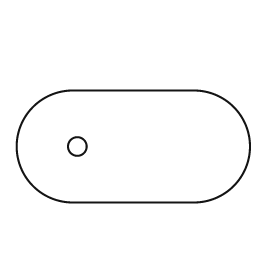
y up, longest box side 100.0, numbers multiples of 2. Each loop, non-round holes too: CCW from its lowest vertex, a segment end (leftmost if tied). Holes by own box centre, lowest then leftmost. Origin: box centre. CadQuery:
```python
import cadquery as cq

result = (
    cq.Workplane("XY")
    .moveTo(-26.0, -24.0)
    .lineTo(26.0, -24.0)
    .threePointArc((50.0, 0.0), (26.0, 24.0))
    .lineTo(-26.0, 24.0)
    .threePointArc((-50.0, 0.0), (-26.0, -24.0))
    .close()
    .moveTo(-24.0, 0.0)
    .circle(4.0)
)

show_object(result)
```